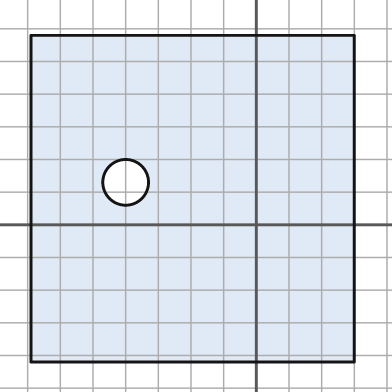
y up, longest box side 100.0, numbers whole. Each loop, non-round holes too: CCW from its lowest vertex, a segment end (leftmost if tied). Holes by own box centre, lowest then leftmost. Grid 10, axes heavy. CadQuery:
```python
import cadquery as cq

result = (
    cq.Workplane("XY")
    .moveTo(-69.0, -42.0)
    .lineTo(30.0, -42.0)
    .lineTo(30.0, 58.0)
    .lineTo(-69.0, 58.0)
    .close()
    .moveTo(-40.0, 13.0)
    .circle(7.0)
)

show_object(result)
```